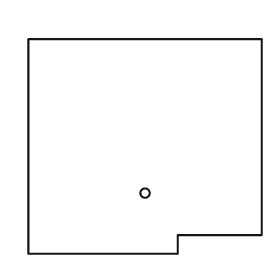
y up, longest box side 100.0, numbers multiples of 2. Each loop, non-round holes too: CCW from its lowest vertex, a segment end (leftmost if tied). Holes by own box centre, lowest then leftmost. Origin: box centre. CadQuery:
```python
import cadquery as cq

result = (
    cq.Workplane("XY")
    .moveTo(-50.0, -46.0)
    .lineTo(14.0, -46.0)
    .lineTo(14.0, -38.0)
    .lineTo(50.0, -38.0)
    .lineTo(50.0, 46.0)
    .lineTo(-50.0, 46.0)
    .close()
    .moveTo(0.0, -20.0)
    .circle(2.0)
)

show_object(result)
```